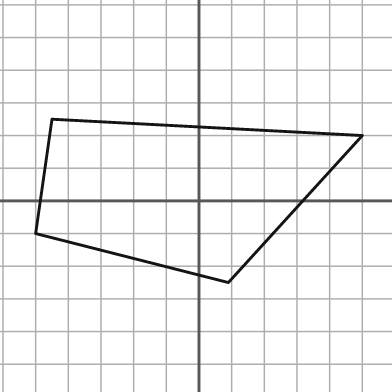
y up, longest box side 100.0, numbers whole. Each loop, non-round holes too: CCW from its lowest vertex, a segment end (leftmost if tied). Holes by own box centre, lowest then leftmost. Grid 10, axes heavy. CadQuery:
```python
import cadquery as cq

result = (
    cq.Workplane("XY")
    .moveTo(9.0, -25.0)
    .lineTo(50.0, 20.0)
    .lineTo(-45.0, 25.0)
    .lineTo(-50.0, -10.0)
    .close()
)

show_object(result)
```